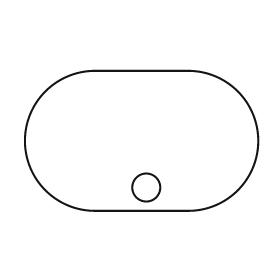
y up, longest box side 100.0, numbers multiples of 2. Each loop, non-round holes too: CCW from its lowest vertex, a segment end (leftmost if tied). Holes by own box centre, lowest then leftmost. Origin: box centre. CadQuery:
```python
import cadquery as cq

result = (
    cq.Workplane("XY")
    .moveTo(-20.0, -30.0)
    .lineTo(20.0, -30.0)
    .threePointArc((50.0, 0.0), (20.0, 30.0))
    .lineTo(-20.0, 30.0)
    .threePointArc((-50.0, 0.0), (-20.0, -30.0))
    .close()
    .moveTo(2.0, -20.0)
    .circle(6.0)
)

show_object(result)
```